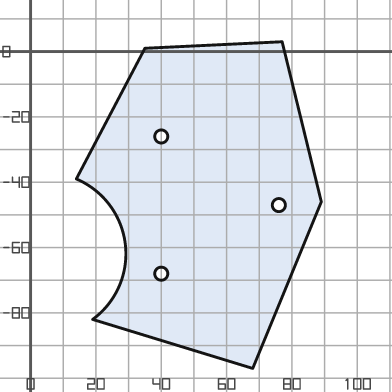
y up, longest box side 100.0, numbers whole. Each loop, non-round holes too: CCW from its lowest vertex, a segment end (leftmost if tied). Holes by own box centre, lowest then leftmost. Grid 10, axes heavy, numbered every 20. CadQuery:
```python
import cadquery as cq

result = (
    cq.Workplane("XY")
    .moveTo(68.0, -97.0)
    .lineTo(89.0, -46.0)
    .lineTo(77.0, 3.0)
    .lineTo(35.0, 1.0)
    .lineTo(14.0, -39.0)
    .threePointArc((29.0, -59.0), (19.0, -82.0))
    .close()
    .moveTo(40.0, -68.0)
    .circle(2.0)
    .moveTo(76.0, -47.0)
    .circle(2.0)
    .moveTo(40.0, -26.0)
    .circle(2.0)
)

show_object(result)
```